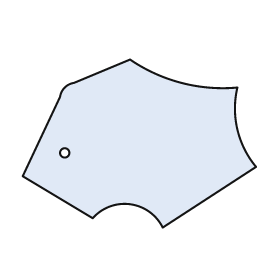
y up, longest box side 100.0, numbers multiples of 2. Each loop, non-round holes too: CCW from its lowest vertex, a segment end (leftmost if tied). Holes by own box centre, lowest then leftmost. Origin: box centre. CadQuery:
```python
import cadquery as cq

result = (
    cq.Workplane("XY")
    .moveTo(10.0, -36.0)
    .lineTo(50.0, -10.0)
    .threePointArc((42.0, 6.0), (42.0, 24.0))
    .threePointArc((18.0, 26.0), (-4.0, 36.0))
    .lineTo(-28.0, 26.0)
    .threePointArc((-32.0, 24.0), (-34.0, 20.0))
    .lineTo(-50.0, -14.0)
    .lineTo(-20.0, -32.0)
    .threePointArc((-4.0, -26.0), (10.0, -36.0))
    .close()
    .moveTo(-32.0, -4.0)
    .circle(2.0)
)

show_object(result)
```